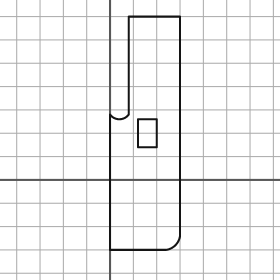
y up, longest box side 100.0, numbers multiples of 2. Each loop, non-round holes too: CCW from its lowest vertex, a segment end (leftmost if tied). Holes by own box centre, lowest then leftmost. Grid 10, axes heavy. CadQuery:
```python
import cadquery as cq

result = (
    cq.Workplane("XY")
    .moveTo(0.0, -30.0)
    .lineTo(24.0, -30.0)
    .threePointArc((28.0, -28.0), (30.0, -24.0))
    .lineTo(30.0, 70.0)
    .lineTo(8.0, 70.0)
    .lineTo(8.0, 28.0)
    .threePointArc((4.0, 26.0), (0.0, 28.0))
    .close()
    .moveTo(12.0, 14.0)
    .lineTo(20.0, 14.0)
    .lineTo(20.0, 26.0)
    .lineTo(12.0, 26.0)
    .close()
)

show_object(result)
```